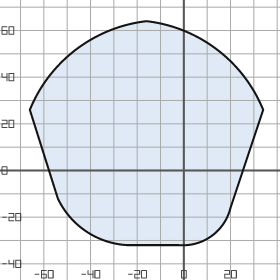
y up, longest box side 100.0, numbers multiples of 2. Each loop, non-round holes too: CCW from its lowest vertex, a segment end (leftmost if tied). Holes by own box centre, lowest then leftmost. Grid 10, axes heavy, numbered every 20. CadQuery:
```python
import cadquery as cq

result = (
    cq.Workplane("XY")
    .moveTo(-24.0, -32.0)
    .lineTo(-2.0, -32.0)
    .threePointArc((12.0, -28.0), (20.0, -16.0))
    .lineTo(34.0, 26.0)
    .threePointArc((14.0, 52.0), (-16.0, 64.0))
    .threePointArc((-46.0, 52.0), (-66.0, 26.0))
    .lineTo(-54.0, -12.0)
    .threePointArc((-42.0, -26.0), (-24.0, -32.0))
    .close()
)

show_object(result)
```